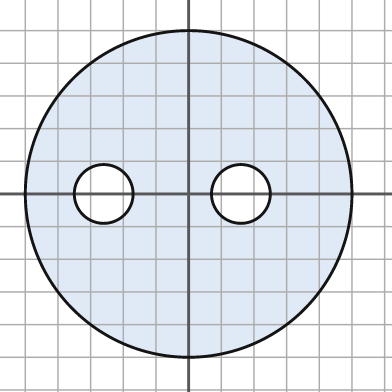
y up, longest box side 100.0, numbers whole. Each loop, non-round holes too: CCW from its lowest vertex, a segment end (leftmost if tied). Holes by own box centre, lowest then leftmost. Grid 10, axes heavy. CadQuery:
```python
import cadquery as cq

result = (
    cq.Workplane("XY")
    .moveTo(0.0, 0.0)
    .circle(50.0)
    .moveTo(-26.0, 0.0)
    .circle(9.0)
    .moveTo(16.0, 0.0)
    .circle(9.0)
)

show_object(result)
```